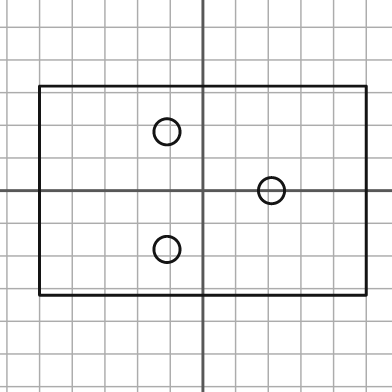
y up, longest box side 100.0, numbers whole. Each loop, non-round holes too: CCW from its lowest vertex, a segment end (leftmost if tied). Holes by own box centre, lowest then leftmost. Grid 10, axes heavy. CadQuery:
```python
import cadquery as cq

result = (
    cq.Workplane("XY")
    .moveTo(-50.0, -32.0)
    .lineTo(50.0, -32.0)
    .lineTo(50.0, 32.0)
    .lineTo(-50.0, 32.0)
    .close()
    .moveTo(-11.0, -18.0)
    .circle(4.0)
    .moveTo(21.0, 0.0)
    .circle(4.0)
    .moveTo(-11.0, 18.0)
    .circle(4.0)
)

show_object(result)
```